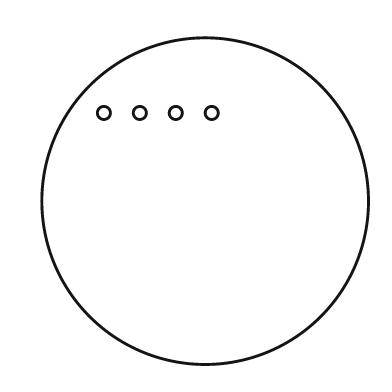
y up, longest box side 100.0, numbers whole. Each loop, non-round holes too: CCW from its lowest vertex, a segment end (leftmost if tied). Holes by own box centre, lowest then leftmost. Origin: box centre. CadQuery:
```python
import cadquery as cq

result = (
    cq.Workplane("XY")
    .moveTo(0.0, 0.0)
    .circle(50.0)
    .moveTo(-31.0, 27.0)
    .circle(2.0)
    .moveTo(-20.0, 27.0)
    .circle(2.0)
    .moveTo(-9.0, 27.0)
    .circle(2.0)
    .moveTo(2.0, 27.0)
    .circle(2.0)
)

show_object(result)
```